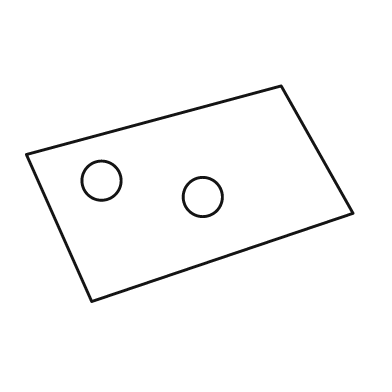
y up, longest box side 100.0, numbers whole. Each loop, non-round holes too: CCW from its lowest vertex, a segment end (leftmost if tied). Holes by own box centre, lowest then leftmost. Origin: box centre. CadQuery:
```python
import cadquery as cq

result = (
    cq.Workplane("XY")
    .moveTo(-30.0, -33.0)
    .lineTo(50.0, -6.0)
    .lineTo(28.0, 33.0)
    .lineTo(-50.0, 12.0)
    .close()
    .moveTo(4.0, -1.0)
    .circle(6.0)
    .moveTo(-27.0, 4.0)
    .circle(6.0)
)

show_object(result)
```